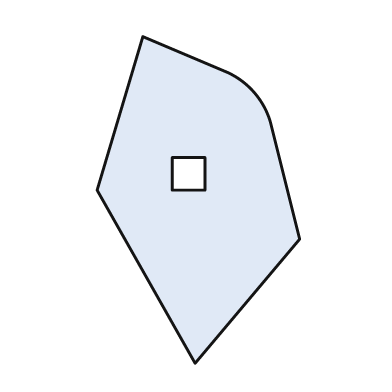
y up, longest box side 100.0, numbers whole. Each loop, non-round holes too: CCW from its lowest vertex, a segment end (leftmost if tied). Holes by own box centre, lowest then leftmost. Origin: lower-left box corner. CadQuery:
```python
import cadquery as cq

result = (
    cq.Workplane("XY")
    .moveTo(30.0, 0.0)
    .lineTo(62.0, 38.0)
    .lineTo(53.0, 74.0)
    .threePointArc((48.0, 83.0), (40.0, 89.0))
    .lineTo(14.0, 100.0)
    .lineTo(0.0, 53.0)
    .close()
    .moveTo(23.0, 53.0)
    .lineTo(33.0, 53.0)
    .lineTo(33.0, 63.0)
    .lineTo(23.0, 63.0)
    .close()
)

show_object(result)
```